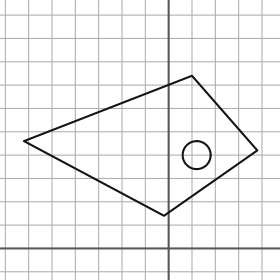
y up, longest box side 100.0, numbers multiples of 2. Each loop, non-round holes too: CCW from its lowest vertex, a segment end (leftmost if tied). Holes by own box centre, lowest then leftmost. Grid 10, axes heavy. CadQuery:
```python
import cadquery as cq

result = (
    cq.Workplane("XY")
    .moveTo(-2.0, 14.0)
    .lineTo(38.0, 42.0)
    .lineTo(10.0, 74.0)
    .lineTo(-62.0, 46.0)
    .close()
    .moveTo(12.0, 40.0)
    .circle(6.0)
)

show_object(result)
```